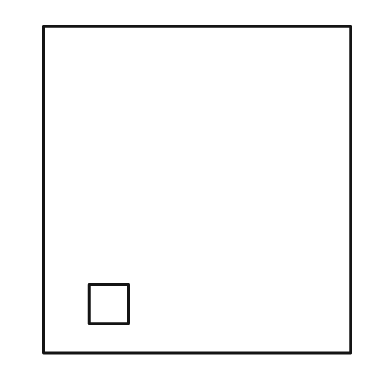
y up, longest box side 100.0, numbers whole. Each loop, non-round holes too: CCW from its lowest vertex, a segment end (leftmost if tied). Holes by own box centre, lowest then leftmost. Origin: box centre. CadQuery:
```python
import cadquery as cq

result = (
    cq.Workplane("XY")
    .moveTo(-47.0, -50.0)
    .lineTo(47.0, -50.0)
    .lineTo(47.0, 50.0)
    .lineTo(-47.0, 50.0)
    .close()
    .moveTo(-33.0, -41.0)
    .lineTo(-21.0, -41.0)
    .lineTo(-21.0, -29.0)
    .lineTo(-33.0, -29.0)
    .close()
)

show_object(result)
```